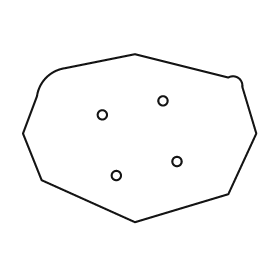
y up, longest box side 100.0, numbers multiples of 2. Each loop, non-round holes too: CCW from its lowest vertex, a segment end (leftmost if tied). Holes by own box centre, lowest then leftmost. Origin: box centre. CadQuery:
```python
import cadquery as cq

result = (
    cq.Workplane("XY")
    .moveTo(-2.0, -36.0)
    .lineTo(38.0, -24.0)
    .lineTo(50.0, 2.0)
    .lineTo(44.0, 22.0)
    .threePointArc((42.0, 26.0), (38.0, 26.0))
    .lineTo(-2.0, 36.0)
    .lineTo(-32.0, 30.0)
    .threePointArc((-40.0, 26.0), (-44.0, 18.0))
    .lineTo(-50.0, 2.0)
    .lineTo(-42.0, -18.0)
    .close()
    .moveTo(-10.0, -16.0)
    .circle(2.0)
    .moveTo(16.0, -10.0)
    .circle(2.0)
    .moveTo(-16.0, 10.0)
    .circle(2.0)
    .moveTo(10.0, 16.0)
    .circle(2.0)
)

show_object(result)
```